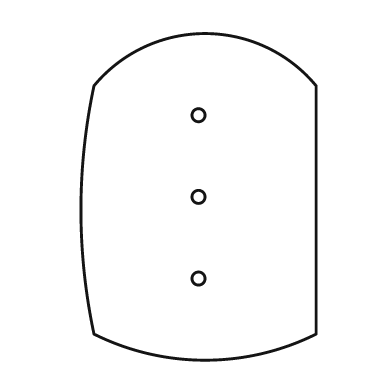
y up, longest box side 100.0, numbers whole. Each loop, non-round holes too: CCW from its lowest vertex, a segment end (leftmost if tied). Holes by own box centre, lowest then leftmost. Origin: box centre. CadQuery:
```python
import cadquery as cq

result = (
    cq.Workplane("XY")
    .moveTo(-32.0, -42.0)
    .threePointArc((2.0, -50.0), (36.0, -42.0))
    .lineTo(36.0, 34.0)
    .threePointArc((2.0, 50.0), (-32.0, 34.0))
    .threePointArc((-36.0, -4.0), (-32.0, -42.0))
    .close()
    .moveTo(0.0, -25.0)
    .circle(2.0)
    .moveTo(0.0, 0.0)
    .circle(2.0)
    .moveTo(0.0, 25.0)
    .circle(2.0)
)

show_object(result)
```